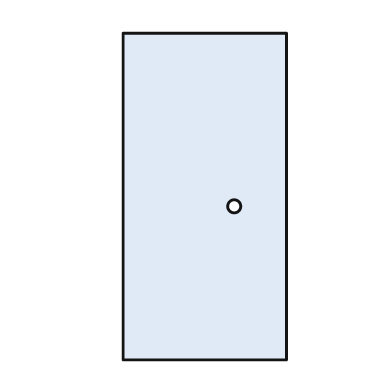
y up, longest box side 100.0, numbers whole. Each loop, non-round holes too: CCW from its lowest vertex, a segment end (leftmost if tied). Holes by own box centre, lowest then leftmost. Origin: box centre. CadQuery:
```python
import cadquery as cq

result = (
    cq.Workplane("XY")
    .moveTo(-25.0, -50.0)
    .lineTo(25.0, -50.0)
    .lineTo(25.0, 50.0)
    .lineTo(-25.0, 50.0)
    .close()
    .moveTo(9.0, -3.0)
    .circle(2.0)
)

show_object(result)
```